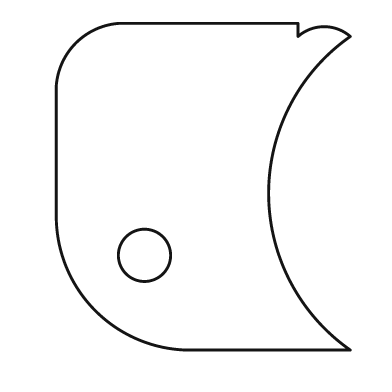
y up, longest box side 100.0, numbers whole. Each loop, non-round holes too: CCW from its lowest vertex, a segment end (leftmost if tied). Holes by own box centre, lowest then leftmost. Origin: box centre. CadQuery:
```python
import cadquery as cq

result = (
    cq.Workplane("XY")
    .moveTo(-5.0, -50.0)
    .lineTo(45.0, -50.0)
    .threePointArc((20.0, -2.0), (45.0, 46.0))
    .threePointArc((37.0, 49.0), (29.0, 46.0))
    .lineTo(29.0, 50.0)
    .lineTo(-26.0, 50.0)
    .threePointArc((-39.0, 44.0), (-45.0, 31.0))
    .lineTo(-45.0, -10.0)
    .threePointArc((-33.0, -38.0), (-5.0, -50.0))
    .close()
    .moveTo(-18.0, -21.0)
    .circle(8.0)
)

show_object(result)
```